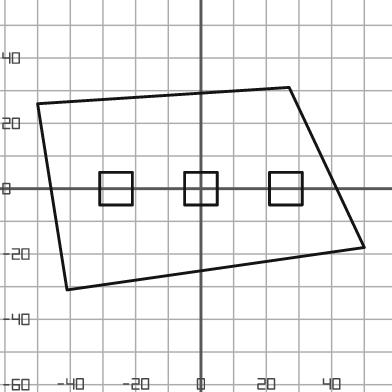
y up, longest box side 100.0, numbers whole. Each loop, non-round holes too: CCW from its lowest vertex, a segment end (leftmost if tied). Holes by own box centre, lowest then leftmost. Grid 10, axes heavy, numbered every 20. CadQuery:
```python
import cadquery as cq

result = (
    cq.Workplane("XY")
    .moveTo(-41.0, -31.0)
    .lineTo(50.0, -18.0)
    .lineTo(27.0, 31.0)
    .lineTo(-50.0, 26.0)
    .close()
    .moveTo(-31.0, -5.0)
    .lineTo(-21.0, -5.0)
    .lineTo(-21.0, 5.0)
    .lineTo(-31.0, 5.0)
    .close()
    .moveTo(-5.0, -5.0)
    .lineTo(5.0, -5.0)
    .lineTo(5.0, 5.0)
    .lineTo(-5.0, 5.0)
    .close()
    .moveTo(21.0, -5.0)
    .lineTo(31.0, -5.0)
    .lineTo(31.0, 5.0)
    .lineTo(21.0, 5.0)
    .close()
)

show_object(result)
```